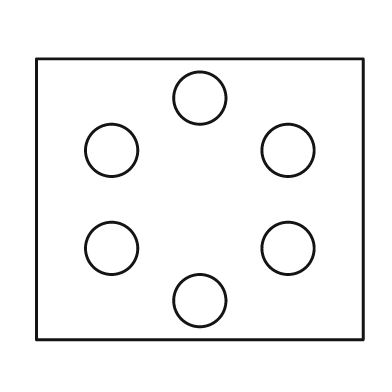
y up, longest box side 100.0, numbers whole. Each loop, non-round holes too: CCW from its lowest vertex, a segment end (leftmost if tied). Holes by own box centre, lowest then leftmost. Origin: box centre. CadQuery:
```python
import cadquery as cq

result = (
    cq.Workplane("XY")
    .moveTo(-50.0, -43.0)
    .lineTo(50.0, -43.0)
    .lineTo(50.0, 43.0)
    .lineTo(-50.0, 43.0)
    .close()
    .moveTo(0.0, -31.0)
    .circle(8.0)
    .moveTo(-27.0, -15.0)
    .circle(8.0)
    .moveTo(27.0, -15.0)
    .circle(8.0)
    .moveTo(-27.0, 15.0)
    .circle(8.0)
    .moveTo(27.0, 15.0)
    .circle(8.0)
    .moveTo(0.0, 31.0)
    .circle(8.0)
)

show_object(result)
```